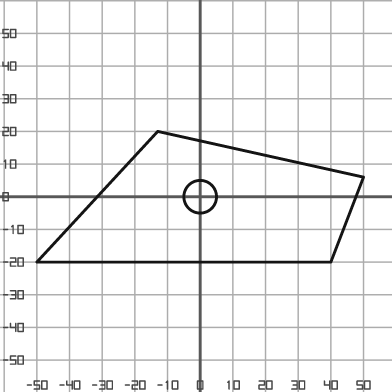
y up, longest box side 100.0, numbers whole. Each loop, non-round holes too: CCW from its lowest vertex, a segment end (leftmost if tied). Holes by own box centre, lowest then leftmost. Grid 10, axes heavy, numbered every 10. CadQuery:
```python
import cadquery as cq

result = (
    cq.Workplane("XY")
    .moveTo(-50.0, -20.0)
    .lineTo(40.0, -20.0)
    .lineTo(50.0, 6.0)
    .lineTo(-13.0, 20.0)
    .close()
    .moveTo(0.0, 0.0)
    .circle(5.0)
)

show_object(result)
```